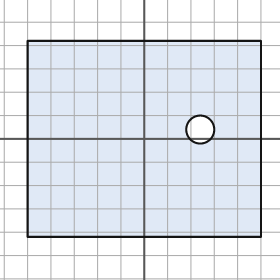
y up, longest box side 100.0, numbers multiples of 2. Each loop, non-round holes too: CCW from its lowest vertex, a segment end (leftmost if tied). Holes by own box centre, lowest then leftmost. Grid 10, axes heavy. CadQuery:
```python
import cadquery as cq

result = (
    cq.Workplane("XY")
    .moveTo(-50.0, -42.0)
    .lineTo(50.0, -42.0)
    .lineTo(50.0, 42.0)
    .lineTo(-50.0, 42.0)
    .close()
    .moveTo(24.0, 4.0)
    .circle(6.0)
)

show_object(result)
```